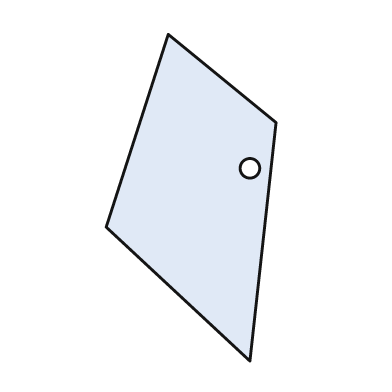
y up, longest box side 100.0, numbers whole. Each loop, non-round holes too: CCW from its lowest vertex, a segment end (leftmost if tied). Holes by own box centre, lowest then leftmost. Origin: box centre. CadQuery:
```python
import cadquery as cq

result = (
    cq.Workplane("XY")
    .moveTo(18.0, -50.0)
    .lineTo(26.0, 23.0)
    .lineTo(-7.0, 50.0)
    .lineTo(-26.0, -9.0)
    .close()
    .moveTo(18.0, 9.0)
    .circle(3.0)
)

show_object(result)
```